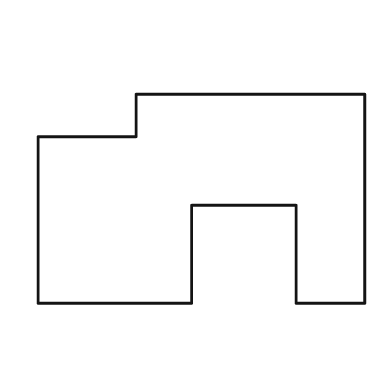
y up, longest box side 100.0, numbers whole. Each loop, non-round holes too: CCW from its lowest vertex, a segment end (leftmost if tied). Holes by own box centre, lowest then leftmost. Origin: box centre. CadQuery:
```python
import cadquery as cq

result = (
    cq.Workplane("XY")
    .moveTo(-50.0, -32.0)
    .lineTo(-3.0, -32.0)
    .lineTo(-3.0, -2.0)
    .lineTo(29.0, -2.0)
    .lineTo(29.0, -32.0)
    .lineTo(50.0, -32.0)
    .lineTo(50.0, 32.0)
    .lineTo(-20.0, 32.0)
    .lineTo(-20.0, 19.0)
    .lineTo(-50.0, 19.0)
    .close()
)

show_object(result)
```